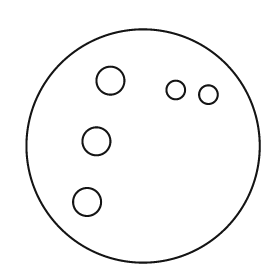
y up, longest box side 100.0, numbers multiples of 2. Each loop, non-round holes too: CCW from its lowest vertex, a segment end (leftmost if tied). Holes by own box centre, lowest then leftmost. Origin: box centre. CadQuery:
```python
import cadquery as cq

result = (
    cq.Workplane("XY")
    .moveTo(0.0, 0.0)
    .circle(50.0)
    .moveTo(-24.0, -24.0)
    .circle(6.0)
    .moveTo(-20.0, 2.0)
    .circle(6.0)
    .moveTo(28.0, 22.0)
    .circle(4.0)
    .moveTo(14.0, 24.0)
    .circle(4.0)
    .moveTo(-14.0, 28.0)
    .circle(6.0)
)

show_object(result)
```